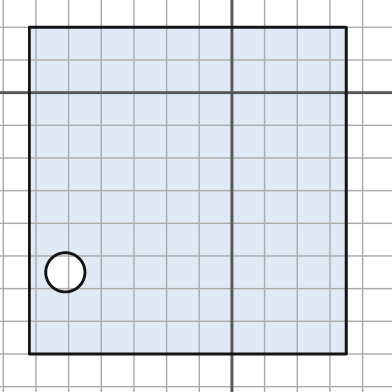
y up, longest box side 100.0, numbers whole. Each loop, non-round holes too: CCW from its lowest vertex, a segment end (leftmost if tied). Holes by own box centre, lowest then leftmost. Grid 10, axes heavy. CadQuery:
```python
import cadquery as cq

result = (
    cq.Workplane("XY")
    .moveTo(-62.0, -80.0)
    .lineTo(35.0, -80.0)
    .lineTo(35.0, 20.0)
    .lineTo(-62.0, 20.0)
    .close()
    .moveTo(-51.0, -55.0)
    .circle(6.0)
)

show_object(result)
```